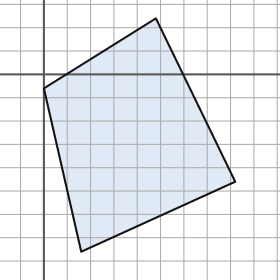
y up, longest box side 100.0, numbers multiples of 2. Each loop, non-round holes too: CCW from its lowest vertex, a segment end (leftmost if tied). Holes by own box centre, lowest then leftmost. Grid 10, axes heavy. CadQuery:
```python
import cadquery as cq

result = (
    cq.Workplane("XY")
    .moveTo(16.0, -76.0)
    .lineTo(82.0, -46.0)
    .lineTo(48.0, 24.0)
    .lineTo(0.0, -6.0)
    .close()
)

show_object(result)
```